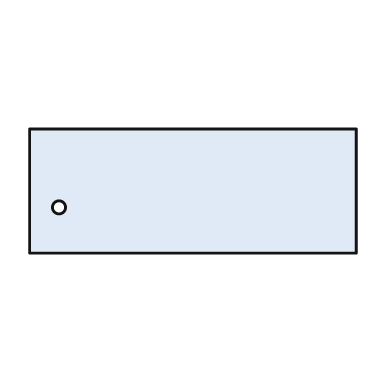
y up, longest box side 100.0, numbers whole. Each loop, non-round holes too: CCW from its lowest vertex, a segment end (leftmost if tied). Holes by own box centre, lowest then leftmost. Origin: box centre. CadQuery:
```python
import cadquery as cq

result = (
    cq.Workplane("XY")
    .moveTo(-50.0, -19.0)
    .lineTo(50.0, -19.0)
    .lineTo(50.0, 19.0)
    .lineTo(-50.0, 19.0)
    .close()
    .moveTo(-41.0, -5.0)
    .circle(2.0)
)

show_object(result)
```